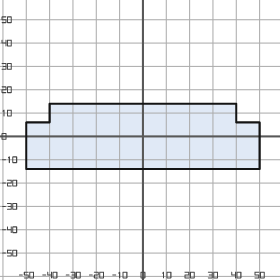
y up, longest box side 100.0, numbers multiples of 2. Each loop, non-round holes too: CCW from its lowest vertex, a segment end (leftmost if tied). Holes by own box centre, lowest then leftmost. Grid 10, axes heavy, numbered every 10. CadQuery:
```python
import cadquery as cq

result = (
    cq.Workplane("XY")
    .moveTo(-50.0, -14.0)
    .lineTo(50.0, -14.0)
    .lineTo(50.0, 6.0)
    .lineTo(40.0, 6.0)
    .lineTo(40.0, 14.0)
    .lineTo(-40.0, 14.0)
    .lineTo(-40.0, 6.0)
    .lineTo(-50.0, 6.0)
    .close()
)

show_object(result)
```